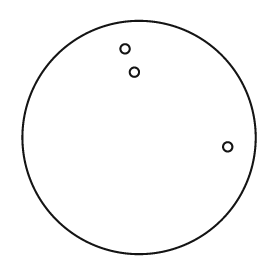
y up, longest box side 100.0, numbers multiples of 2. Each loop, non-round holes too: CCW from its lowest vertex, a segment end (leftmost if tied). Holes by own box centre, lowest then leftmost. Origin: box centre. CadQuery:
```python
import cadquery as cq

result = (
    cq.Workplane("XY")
    .moveTo(0.0, 0.0)
    .circle(50.0)
    .moveTo(38.0, -4.0)
    .circle(2.0)
    .moveTo(-2.0, 28.0)
    .circle(2.0)
    .moveTo(-6.0, 38.0)
    .circle(2.0)
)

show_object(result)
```